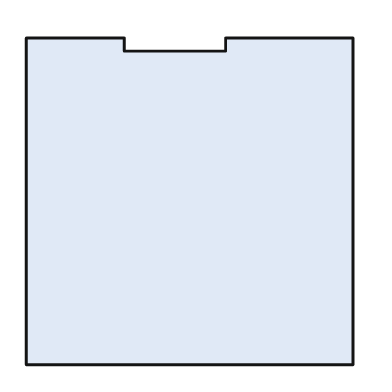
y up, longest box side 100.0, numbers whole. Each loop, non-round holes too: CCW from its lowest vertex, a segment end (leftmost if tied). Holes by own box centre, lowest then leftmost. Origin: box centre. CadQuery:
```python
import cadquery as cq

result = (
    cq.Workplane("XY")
    .moveTo(-50.0, -50.0)
    .lineTo(50.0, -50.0)
    .lineTo(50.0, 50.0)
    .lineTo(11.0, 50.0)
    .lineTo(11.0, 46.0)
    .lineTo(-20.0, 46.0)
    .lineTo(-20.0, 50.0)
    .lineTo(-50.0, 50.0)
    .close()
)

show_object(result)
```